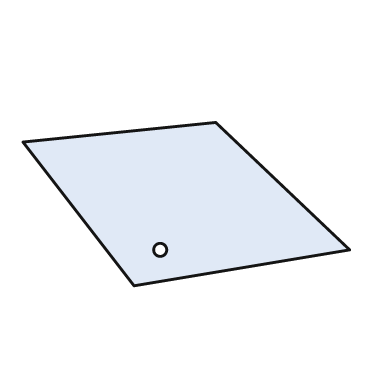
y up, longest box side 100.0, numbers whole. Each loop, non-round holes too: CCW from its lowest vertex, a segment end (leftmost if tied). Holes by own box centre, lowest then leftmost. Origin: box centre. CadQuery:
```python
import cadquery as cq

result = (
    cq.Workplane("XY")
    .moveTo(-16.0, -25.0)
    .lineTo(50.0, -14.0)
    .lineTo(9.0, 25.0)
    .lineTo(-50.0, 19.0)
    .close()
    .moveTo(-8.0, -14.0)
    .circle(2.0)
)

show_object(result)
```